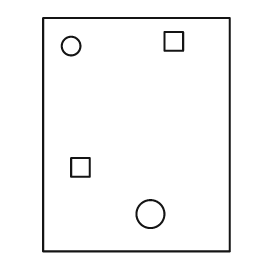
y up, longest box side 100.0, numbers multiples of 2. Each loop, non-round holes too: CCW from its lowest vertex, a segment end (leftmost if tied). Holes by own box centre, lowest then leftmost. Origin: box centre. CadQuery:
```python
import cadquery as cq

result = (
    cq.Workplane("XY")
    .moveTo(-40.0, -50.0)
    .lineTo(40.0, -50.0)
    .lineTo(40.0, 50.0)
    .lineTo(-40.0, 50.0)
    .close()
    .moveTo(6.0, -34.0)
    .circle(6.0)
    .moveTo(-28.0, -18.0)
    .lineTo(-20.0, -18.0)
    .lineTo(-20.0, -10.0)
    .lineTo(-28.0, -10.0)
    .close()
    .moveTo(-28.0, 38.0)
    .circle(4.0)
    .moveTo(12.0, 36.0)
    .lineTo(20.0, 36.0)
    .lineTo(20.0, 44.0)
    .lineTo(12.0, 44.0)
    .close()
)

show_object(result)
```